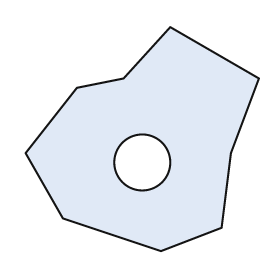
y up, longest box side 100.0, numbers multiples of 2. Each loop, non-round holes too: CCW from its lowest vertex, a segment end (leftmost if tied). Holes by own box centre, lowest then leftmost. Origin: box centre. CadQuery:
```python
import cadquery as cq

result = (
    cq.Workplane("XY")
    .moveTo(8.0, -48.0)
    .lineTo(34.0, -38.0)
    .lineTo(38.0, -6.0)
    .lineTo(50.0, 26.0)
    .lineTo(12.0, 48.0)
    .lineTo(-8.0, 26.0)
    .lineTo(-28.0, 22.0)
    .lineTo(-50.0, -6.0)
    .lineTo(-34.0, -34.0)
    .close()
    .moveTo(0.0, -10.0)
    .circle(12.0)
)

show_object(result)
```